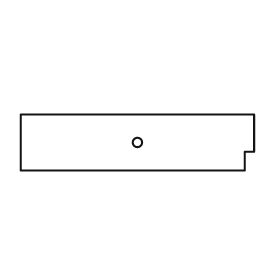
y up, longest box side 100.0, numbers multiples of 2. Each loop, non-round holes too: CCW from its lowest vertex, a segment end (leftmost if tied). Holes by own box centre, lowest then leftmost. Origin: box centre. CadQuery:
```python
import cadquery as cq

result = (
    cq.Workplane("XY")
    .moveTo(-50.0, -12.0)
    .lineTo(46.0, -12.0)
    .lineTo(46.0, -4.0)
    .lineTo(50.0, -4.0)
    .lineTo(50.0, 12.0)
    .lineTo(-50.0, 12.0)
    .close()
    .moveTo(0.0, 0.0)
    .circle(2.0)
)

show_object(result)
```